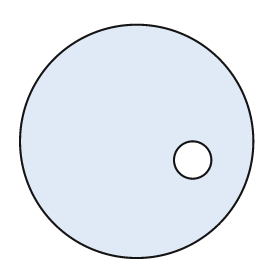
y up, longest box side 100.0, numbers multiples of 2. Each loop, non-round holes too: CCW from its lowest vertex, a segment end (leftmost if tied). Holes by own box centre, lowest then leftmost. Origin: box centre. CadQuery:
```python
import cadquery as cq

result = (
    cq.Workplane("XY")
    .moveTo(0.0, 0.0)
    .circle(50.0)
    .moveTo(24.0, -8.0)
    .circle(8.0)
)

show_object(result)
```